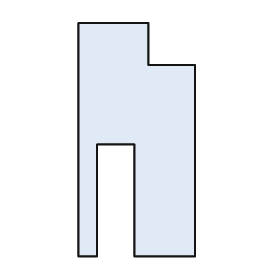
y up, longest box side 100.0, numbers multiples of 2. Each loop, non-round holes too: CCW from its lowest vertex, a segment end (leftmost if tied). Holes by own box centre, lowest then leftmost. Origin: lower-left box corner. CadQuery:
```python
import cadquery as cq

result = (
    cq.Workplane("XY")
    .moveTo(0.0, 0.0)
    .lineTo(8.0, 0.0)
    .lineTo(8.0, 48.0)
    .lineTo(24.0, 48.0)
    .lineTo(24.0, 0.0)
    .lineTo(50.0, 0.0)
    .lineTo(50.0, 82.0)
    .lineTo(30.0, 82.0)
    .lineTo(30.0, 100.0)
    .lineTo(0.0, 100.0)
    .close()
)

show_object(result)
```